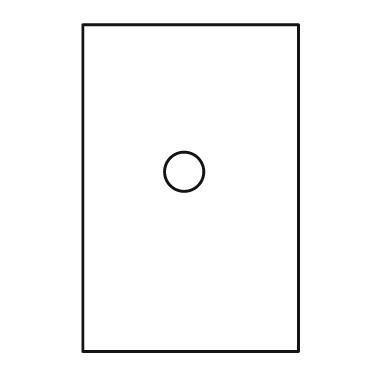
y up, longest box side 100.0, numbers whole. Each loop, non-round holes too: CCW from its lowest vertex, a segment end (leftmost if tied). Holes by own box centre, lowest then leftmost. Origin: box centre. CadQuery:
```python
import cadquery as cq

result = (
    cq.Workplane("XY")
    .moveTo(-33.0, -50.0)
    .lineTo(33.0, -50.0)
    .lineTo(33.0, 50.0)
    .lineTo(-33.0, 50.0)
    .close()
    .moveTo(-2.0, 5.0)
    .circle(6.0)
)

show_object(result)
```